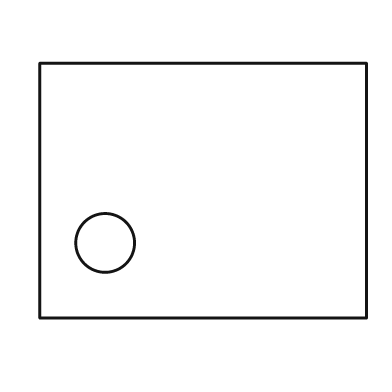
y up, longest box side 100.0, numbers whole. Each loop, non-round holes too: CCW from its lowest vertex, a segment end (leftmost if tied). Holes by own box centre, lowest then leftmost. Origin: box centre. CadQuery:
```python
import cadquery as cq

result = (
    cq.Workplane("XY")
    .moveTo(-50.0, -39.0)
    .lineTo(50.0, -39.0)
    .lineTo(50.0, 39.0)
    .lineTo(-50.0, 39.0)
    .close()
    .moveTo(-30.0, -16.0)
    .circle(9.0)
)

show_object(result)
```